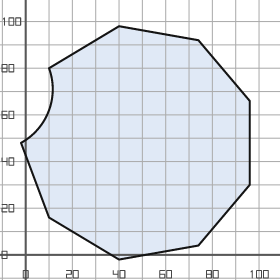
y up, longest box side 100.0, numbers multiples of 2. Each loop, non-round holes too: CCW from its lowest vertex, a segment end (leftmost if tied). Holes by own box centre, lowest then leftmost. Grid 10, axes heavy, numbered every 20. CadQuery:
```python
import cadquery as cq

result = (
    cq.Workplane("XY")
    .moveTo(40.0, -2.0)
    .lineTo(74.0, 4.0)
    .lineTo(96.0, 30.0)
    .lineTo(96.0, 66.0)
    .lineTo(74.0, 92.0)
    .lineTo(40.0, 98.0)
    .lineTo(10.0, 80.0)
    .threePointArc((10.0, 62.0), (-2.0, 48.0))
    .lineTo(10.0, 16.0)
    .close()
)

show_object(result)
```